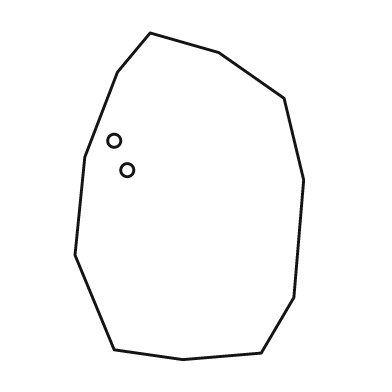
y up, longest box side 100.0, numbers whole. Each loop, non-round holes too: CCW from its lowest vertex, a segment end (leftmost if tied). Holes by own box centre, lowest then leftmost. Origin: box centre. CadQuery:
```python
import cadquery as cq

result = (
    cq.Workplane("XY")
    .moveTo(-2.0, -50.0)
    .lineTo(22.0, -48.0)
    .lineTo(32.0, -31.0)
    .lineTo(35.0, 5.0)
    .lineTo(29.0, 30.0)
    .lineTo(9.0, 44.0)
    .lineTo(-12.0, 50.0)
    .lineTo(-22.0, 38.0)
    .lineTo(-32.0, 12.0)
    .lineTo(-35.0, -18.0)
    .lineTo(-23.0, -47.0)
    .close()
    .moveTo(-19.0, 8.0)
    .circle(2.0)
    .moveTo(-23.0, 17.0)
    .circle(2.0)
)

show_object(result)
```